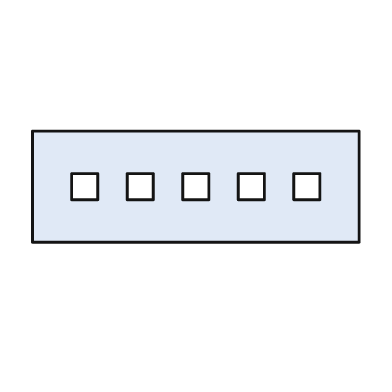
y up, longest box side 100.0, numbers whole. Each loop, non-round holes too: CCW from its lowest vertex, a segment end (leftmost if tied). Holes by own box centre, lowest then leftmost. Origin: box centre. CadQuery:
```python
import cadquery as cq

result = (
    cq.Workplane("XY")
    .moveTo(-50.0, -17.0)
    .lineTo(50.0, -17.0)
    .lineTo(50.0, 17.0)
    .lineTo(-50.0, 17.0)
    .close()
    .moveTo(-38.0, -4.0)
    .lineTo(-30.0, -4.0)
    .lineTo(-30.0, 4.0)
    .lineTo(-38.0, 4.0)
    .close()
    .moveTo(-21.0, -4.0)
    .lineTo(-13.0, -4.0)
    .lineTo(-13.0, 4.0)
    .lineTo(-21.0, 4.0)
    .close()
    .moveTo(-4.0, -4.0)
    .lineTo(4.0, -4.0)
    .lineTo(4.0, 4.0)
    .lineTo(-4.0, 4.0)
    .close()
    .moveTo(13.0, -4.0)
    .lineTo(21.0, -4.0)
    .lineTo(21.0, 4.0)
    .lineTo(13.0, 4.0)
    .close()
    .moveTo(30.0, -4.0)
    .lineTo(38.0, -4.0)
    .lineTo(38.0, 4.0)
    .lineTo(30.0, 4.0)
    .close()
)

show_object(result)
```